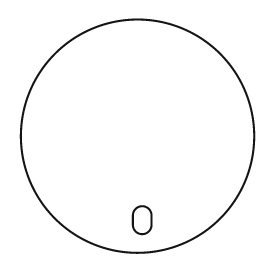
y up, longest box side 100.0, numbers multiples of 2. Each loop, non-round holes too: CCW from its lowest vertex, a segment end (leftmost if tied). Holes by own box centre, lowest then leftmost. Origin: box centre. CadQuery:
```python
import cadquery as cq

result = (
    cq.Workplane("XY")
    .moveTo(0.0, 0.0)
    .circle(50.0)
    .moveTo(-2.0, -38.0)
    .threePointArc((2.0, -42.0), (6.0, -38.0))
    .lineTo(6.0, -34.0)
    .threePointArc((2.0, -30.0), (-2.0, -34.0))
    .close()
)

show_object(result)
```